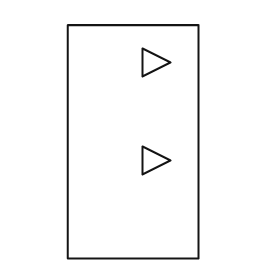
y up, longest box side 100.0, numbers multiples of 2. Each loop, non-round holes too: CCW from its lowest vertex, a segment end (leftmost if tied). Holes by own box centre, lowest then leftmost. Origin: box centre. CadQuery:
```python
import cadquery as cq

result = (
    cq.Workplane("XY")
    .moveTo(-28.0, -50.0)
    .lineTo(28.0, -50.0)
    .lineTo(28.0, 50.0)
    .lineTo(-28.0, 50.0)
    .close()
    .moveTo(4.0, -14.0)
    .lineTo(16.0, -8.0)
    .lineTo(4.0, -2.0)
    .close()
    .moveTo(4.0, 28.0)
    .lineTo(16.0, 34.0)
    .lineTo(4.0, 40.0)
    .close()
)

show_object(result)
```